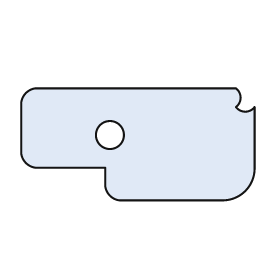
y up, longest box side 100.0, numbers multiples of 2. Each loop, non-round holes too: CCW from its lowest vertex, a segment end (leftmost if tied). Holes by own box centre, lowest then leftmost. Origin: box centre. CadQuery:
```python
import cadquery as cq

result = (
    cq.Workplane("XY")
    .moveTo(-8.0, -24.0)
    .lineTo(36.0, -24.0)
    .threePointArc((46.0, -20.0), (50.0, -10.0))
    .lineTo(50.0, 16.0)
    .threePointArc((46.0, 14.0), (42.0, 16.0))
    .threePointArc((44.0, 20.0), (42.0, 24.0))
    .lineTo(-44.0, 24.0)
    .threePointArc((-48.0, 22.0), (-50.0, 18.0))
    .lineTo(-50.0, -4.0)
    .threePointArc((-48.0, -8.0), (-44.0, -10.0))
    .lineTo(-14.0, -10.0)
    .lineTo(-14.0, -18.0)
    .threePointArc((-12.0, -22.0), (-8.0, -24.0))
    .close()
    .moveTo(-12.0, 4.0)
    .circle(6.0)
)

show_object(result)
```